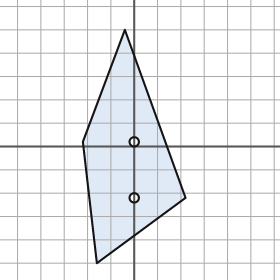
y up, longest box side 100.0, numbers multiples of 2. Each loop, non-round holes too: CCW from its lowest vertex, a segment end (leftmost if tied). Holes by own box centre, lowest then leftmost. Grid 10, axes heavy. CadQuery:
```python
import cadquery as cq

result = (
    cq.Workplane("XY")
    .moveTo(-16.0, -50.0)
    .lineTo(22.0, -22.0)
    .lineTo(-4.0, 50.0)
    .lineTo(-22.0, 2.0)
    .close()
    .moveTo(0.0, -22.0)
    .circle(2.0)
    .moveTo(0.0, 2.0)
    .circle(2.0)
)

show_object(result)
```